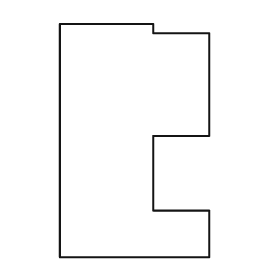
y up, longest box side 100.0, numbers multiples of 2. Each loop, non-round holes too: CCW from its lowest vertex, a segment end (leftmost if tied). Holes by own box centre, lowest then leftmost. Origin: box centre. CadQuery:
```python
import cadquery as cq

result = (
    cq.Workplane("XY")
    .moveTo(-32.0, -50.0)
    .lineTo(32.0, -50.0)
    .lineTo(32.0, -30.0)
    .lineTo(8.0, -30.0)
    .lineTo(8.0, 2.0)
    .lineTo(32.0, 2.0)
    .lineTo(32.0, 46.0)
    .lineTo(8.0, 46.0)
    .lineTo(8.0, 50.0)
    .lineTo(-32.0, 50.0)
    .close()
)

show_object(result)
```